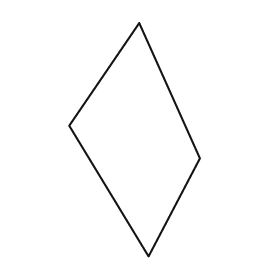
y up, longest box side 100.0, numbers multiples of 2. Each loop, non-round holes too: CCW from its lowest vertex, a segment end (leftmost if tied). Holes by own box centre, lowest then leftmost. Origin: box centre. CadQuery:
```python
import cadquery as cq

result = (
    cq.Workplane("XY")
    .moveTo(6.0, -50.0)
    .lineTo(28.0, -8.0)
    .lineTo(2.0, 50.0)
    .lineTo(-28.0, 6.0)
    .close()
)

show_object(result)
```